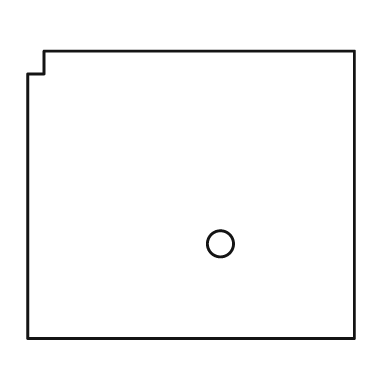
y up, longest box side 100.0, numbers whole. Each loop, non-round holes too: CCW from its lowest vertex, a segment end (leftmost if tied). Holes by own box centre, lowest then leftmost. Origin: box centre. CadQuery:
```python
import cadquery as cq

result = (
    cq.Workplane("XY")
    .moveTo(-50.0, -44.0)
    .lineTo(50.0, -44.0)
    .lineTo(50.0, 44.0)
    .lineTo(-45.0, 44.0)
    .lineTo(-45.0, 37.0)
    .lineTo(-50.0, 37.0)
    .close()
    .moveTo(9.0, -15.0)
    .circle(4.0)
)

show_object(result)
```